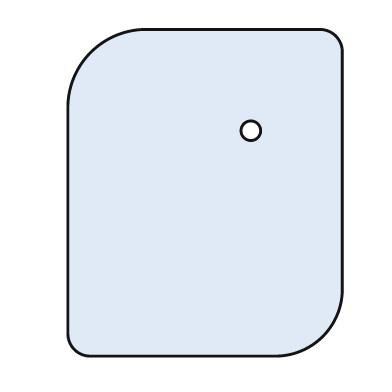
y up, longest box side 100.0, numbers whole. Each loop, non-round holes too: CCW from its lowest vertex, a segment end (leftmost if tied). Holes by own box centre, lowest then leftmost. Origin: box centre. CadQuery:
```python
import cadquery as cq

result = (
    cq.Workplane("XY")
    .moveTo(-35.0, -50.0)
    .lineTo(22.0, -50.0)
    .threePointArc((36.0, -44.0), (42.0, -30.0))
    .lineTo(42.0, 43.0)
    .threePointArc((40.0, 48.0), (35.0, 50.0))
    .lineTo(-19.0, 50.0)
    .threePointArc((-35.0, 43.0), (-42.0, 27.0))
    .lineTo(-42.0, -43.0)
    .threePointArc((-40.0, -48.0), (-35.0, -50.0))
    .close()
    .moveTo(14.0, 19.0)
    .circle(3.0)
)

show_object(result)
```